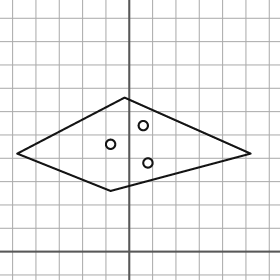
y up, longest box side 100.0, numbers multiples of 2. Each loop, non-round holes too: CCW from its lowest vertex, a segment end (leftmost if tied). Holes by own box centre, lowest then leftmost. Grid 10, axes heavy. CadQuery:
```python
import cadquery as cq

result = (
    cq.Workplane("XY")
    .moveTo(-8.0, 26.0)
    .lineTo(52.0, 42.0)
    .lineTo(-2.0, 66.0)
    .lineTo(-48.0, 42.0)
    .close()
    .moveTo(8.0, 38.0)
    .circle(2.0)
    .moveTo(-8.0, 46.0)
    .circle(2.0)
    .moveTo(6.0, 54.0)
    .circle(2.0)
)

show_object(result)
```